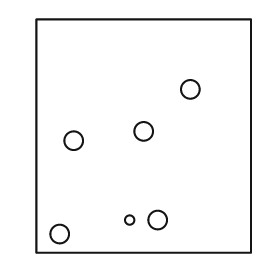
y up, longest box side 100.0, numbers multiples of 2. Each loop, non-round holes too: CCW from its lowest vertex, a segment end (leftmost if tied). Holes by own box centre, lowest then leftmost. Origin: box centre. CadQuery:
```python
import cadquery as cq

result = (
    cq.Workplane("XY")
    .moveTo(-46.0, -50.0)
    .lineTo(46.0, -50.0)
    .lineTo(46.0, 50.0)
    .lineTo(-46.0, 50.0)
    .close()
    .moveTo(-36.0, -42.0)
    .circle(4.0)
    .moveTo(-6.0, -36.0)
    .circle(2.0)
    .moveTo(6.0, -36.0)
    .circle(4.0)
    .moveTo(-30.0, -2.0)
    .circle(4.0)
    .moveTo(0.0, 2.0)
    .circle(4.0)
    .moveTo(20.0, 20.0)
    .circle(4.0)
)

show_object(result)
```